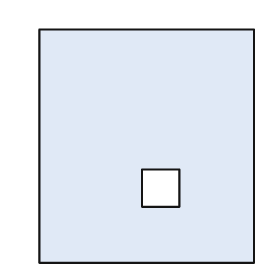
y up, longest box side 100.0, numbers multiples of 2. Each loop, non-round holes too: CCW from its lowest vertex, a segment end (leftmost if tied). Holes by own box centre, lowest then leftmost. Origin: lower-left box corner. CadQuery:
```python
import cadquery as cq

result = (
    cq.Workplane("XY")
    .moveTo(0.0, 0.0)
    .lineTo(92.0, 0.0)
    .lineTo(92.0, 100.0)
    .lineTo(0.0, 100.0)
    .close()
    .moveTo(44.0, 24.0)
    .lineTo(60.0, 24.0)
    .lineTo(60.0, 40.0)
    .lineTo(44.0, 40.0)
    .close()
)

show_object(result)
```